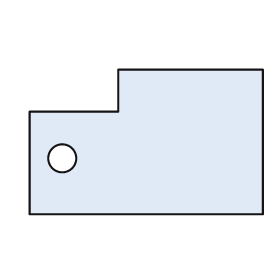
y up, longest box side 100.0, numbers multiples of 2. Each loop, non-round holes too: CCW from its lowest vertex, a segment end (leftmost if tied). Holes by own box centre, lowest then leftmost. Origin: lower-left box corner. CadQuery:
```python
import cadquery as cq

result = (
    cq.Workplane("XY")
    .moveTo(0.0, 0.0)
    .lineTo(100.0, 0.0)
    .lineTo(100.0, 62.0)
    .lineTo(38.0, 62.0)
    .lineTo(38.0, 44.0)
    .lineTo(0.0, 44.0)
    .close()
    .moveTo(14.0, 24.0)
    .circle(6.0)
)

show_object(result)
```